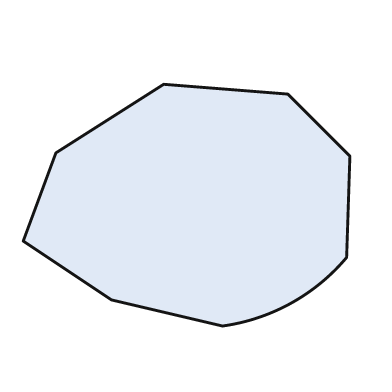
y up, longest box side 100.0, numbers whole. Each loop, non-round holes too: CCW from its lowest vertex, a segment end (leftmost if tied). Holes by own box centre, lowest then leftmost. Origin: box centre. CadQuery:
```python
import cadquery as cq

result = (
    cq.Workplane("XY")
    .moveTo(11.0, -37.0)
    .threePointArc((32.0, -30.0), (49.0, -16.0))
    .lineTo(50.0, 15.0)
    .lineTo(31.0, 34.0)
    .lineTo(-7.0, 37.0)
    .lineTo(-40.0, 16.0)
    .lineTo(-50.0, -11.0)
    .lineTo(-23.0, -29.0)
    .close()
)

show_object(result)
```